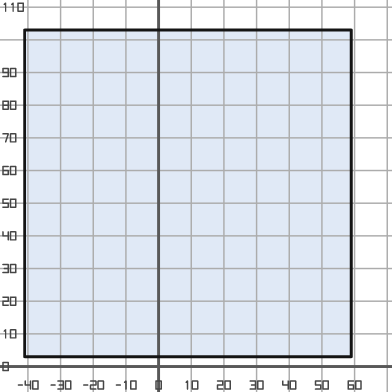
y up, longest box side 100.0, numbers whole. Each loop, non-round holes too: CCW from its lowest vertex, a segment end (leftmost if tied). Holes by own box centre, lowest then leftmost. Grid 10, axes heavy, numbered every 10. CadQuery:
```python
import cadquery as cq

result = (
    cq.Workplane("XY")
    .moveTo(-41.0, 3.0)
    .lineTo(59.0, 3.0)
    .lineTo(59.0, 103.0)
    .lineTo(-41.0, 103.0)
    .close()
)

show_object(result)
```